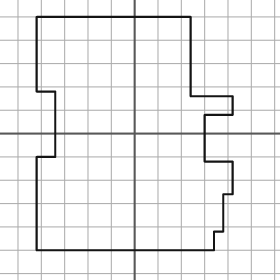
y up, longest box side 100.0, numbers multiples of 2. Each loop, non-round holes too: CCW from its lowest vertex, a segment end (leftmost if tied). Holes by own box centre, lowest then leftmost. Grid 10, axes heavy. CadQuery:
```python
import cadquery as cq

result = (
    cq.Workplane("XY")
    .moveTo(-42.0, -50.0)
    .lineTo(34.0, -50.0)
    .lineTo(34.0, -42.0)
    .lineTo(38.0, -42.0)
    .lineTo(38.0, -26.0)
    .lineTo(42.0, -26.0)
    .lineTo(42.0, -12.0)
    .lineTo(30.0, -12.0)
    .lineTo(30.0, 8.0)
    .lineTo(42.0, 8.0)
    .lineTo(42.0, 16.0)
    .lineTo(24.0, 16.0)
    .lineTo(24.0, 50.0)
    .lineTo(-42.0, 50.0)
    .lineTo(-42.0, 18.0)
    .lineTo(-34.0, 18.0)
    .lineTo(-34.0, -10.0)
    .lineTo(-42.0, -10.0)
    .close()
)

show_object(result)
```